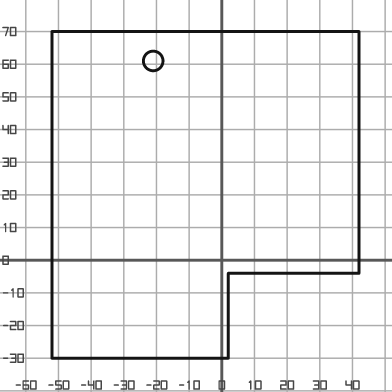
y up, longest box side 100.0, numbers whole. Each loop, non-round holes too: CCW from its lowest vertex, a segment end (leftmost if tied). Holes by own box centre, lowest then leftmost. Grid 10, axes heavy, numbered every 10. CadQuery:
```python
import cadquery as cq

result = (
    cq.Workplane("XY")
    .moveTo(-52.0, -30.0)
    .lineTo(2.0, -30.0)
    .lineTo(2.0, -4.0)
    .lineTo(42.0, -4.0)
    .lineTo(42.0, 70.0)
    .lineTo(-52.0, 70.0)
    .close()
    .moveTo(-21.0, 61.0)
    .circle(3.0)
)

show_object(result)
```